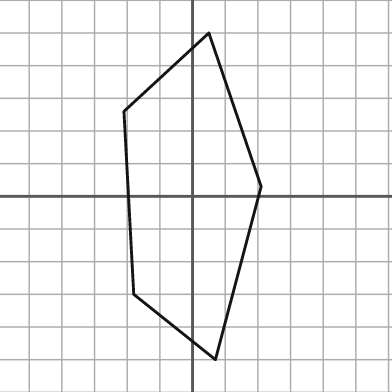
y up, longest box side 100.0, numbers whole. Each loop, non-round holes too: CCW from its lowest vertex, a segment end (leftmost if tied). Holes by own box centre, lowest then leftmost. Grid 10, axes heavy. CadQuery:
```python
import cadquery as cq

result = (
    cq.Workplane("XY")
    .moveTo(7.0, -50.0)
    .lineTo(21.0, 3.0)
    .lineTo(5.0, 50.0)
    .lineTo(-21.0, 26.0)
    .lineTo(-18.0, -30.0)
    .close()
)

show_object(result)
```